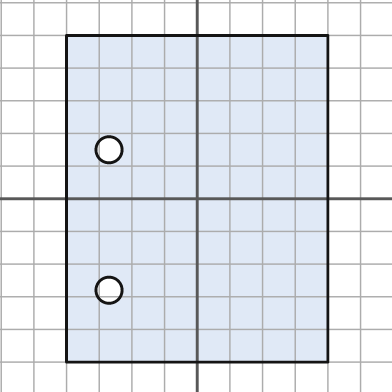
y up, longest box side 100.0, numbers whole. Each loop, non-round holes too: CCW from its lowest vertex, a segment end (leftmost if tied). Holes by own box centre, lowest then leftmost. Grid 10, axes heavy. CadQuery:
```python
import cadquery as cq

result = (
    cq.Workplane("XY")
    .moveTo(-40.0, -50.0)
    .lineTo(40.0, -50.0)
    .lineTo(40.0, 50.0)
    .lineTo(-40.0, 50.0)
    .close()
    .moveTo(-27.0, -28.0)
    .circle(4.0)
    .moveTo(-27.0, 15.0)
    .circle(4.0)
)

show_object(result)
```